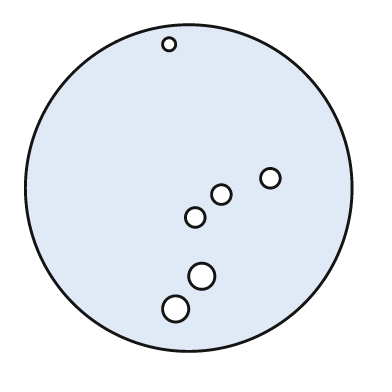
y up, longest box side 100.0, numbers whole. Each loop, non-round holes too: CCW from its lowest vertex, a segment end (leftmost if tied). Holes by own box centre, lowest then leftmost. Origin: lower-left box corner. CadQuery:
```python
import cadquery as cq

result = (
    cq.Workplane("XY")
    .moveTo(50.0, 50.0)
    .circle(50.0)
    .moveTo(46.0, 13.0)
    .circle(4.0)
    .moveTo(54.0, 23.0)
    .circle(4.0)
    .moveTo(52.0, 41.0)
    .circle(3.0)
    .moveTo(60.0, 48.0)
    .circle(3.0)
    .moveTo(75.0, 53.0)
    .circle(3.0)
    .moveTo(44.0, 94.0)
    .circle(2.0)
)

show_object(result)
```